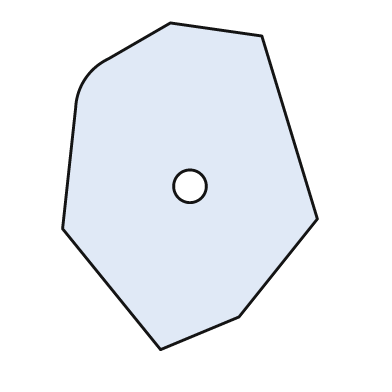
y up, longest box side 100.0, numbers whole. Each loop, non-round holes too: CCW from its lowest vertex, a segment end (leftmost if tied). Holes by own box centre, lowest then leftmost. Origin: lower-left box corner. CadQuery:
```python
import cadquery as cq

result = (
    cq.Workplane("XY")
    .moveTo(30.0, 0.0)
    .lineTo(54.0, 10.0)
    .lineTo(78.0, 40.0)
    .lineTo(61.0, 96.0)
    .lineTo(33.0, 100.0)
    .lineTo(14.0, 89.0)
    .threePointArc((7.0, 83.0), (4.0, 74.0))
    .lineTo(0.0, 37.0)
    .close()
    .moveTo(39.0, 50.0)
    .circle(5.0)
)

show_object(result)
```